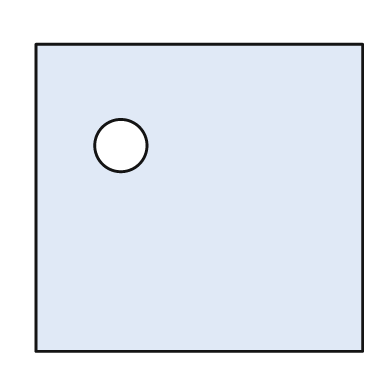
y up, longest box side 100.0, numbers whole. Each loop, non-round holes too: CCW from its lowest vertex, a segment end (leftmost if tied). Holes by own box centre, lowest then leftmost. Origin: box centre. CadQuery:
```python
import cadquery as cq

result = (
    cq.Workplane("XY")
    .moveTo(-50.0, -47.0)
    .lineTo(50.0, -47.0)
    .lineTo(50.0, 47.0)
    .lineTo(-50.0, 47.0)
    .close()
    .moveTo(-24.0, 16.0)
    .circle(8.0)
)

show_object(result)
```